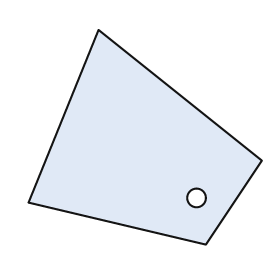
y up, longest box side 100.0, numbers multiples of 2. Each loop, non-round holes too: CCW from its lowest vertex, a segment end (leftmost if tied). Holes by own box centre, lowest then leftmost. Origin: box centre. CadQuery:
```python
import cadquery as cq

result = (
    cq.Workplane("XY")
    .moveTo(26.0, -46.0)
    .lineTo(50.0, -10.0)
    .lineTo(-20.0, 46.0)
    .lineTo(-50.0, -28.0)
    .close()
    .moveTo(22.0, -26.0)
    .circle(4.0)
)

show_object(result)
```